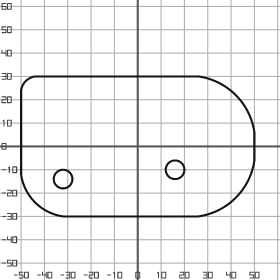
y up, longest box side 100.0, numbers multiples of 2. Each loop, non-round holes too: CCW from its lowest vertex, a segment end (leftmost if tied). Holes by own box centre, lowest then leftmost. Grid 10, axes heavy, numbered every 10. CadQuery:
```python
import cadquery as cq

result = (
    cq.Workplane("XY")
    .moveTo(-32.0, -30.0)
    .lineTo(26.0, -30.0)
    .threePointArc((42.0, -22.0), (50.0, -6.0))
    .lineTo(50.0, 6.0)
    .threePointArc((42.0, 22.0), (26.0, 30.0))
    .lineTo(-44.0, 30.0)
    .threePointArc((-48.0, 28.0), (-50.0, 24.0))
    .lineTo(-50.0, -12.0)
    .threePointArc((-44.0, -24.0), (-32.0, -30.0))
    .close()
    .moveTo(-32.0, -14.0)
    .circle(4.0)
    .moveTo(16.0, -10.0)
    .circle(4.0)
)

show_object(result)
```